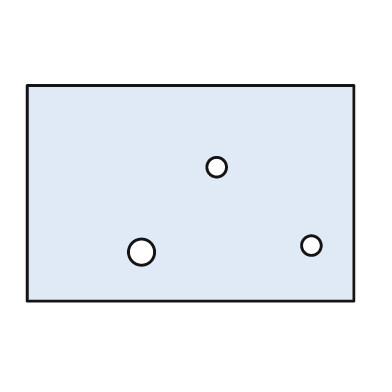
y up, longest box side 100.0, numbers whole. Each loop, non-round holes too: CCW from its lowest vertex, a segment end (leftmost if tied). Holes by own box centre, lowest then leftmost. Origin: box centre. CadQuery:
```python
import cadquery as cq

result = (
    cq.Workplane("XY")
    .moveTo(-50.0, -33.0)
    .lineTo(50.0, -33.0)
    .lineTo(50.0, 33.0)
    .lineTo(-50.0, 33.0)
    .close()
    .moveTo(-15.0, -18.0)
    .circle(4.0)
    .moveTo(37.0, -16.0)
    .circle(3.0)
    .moveTo(8.0, 8.0)
    .circle(3.0)
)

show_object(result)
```